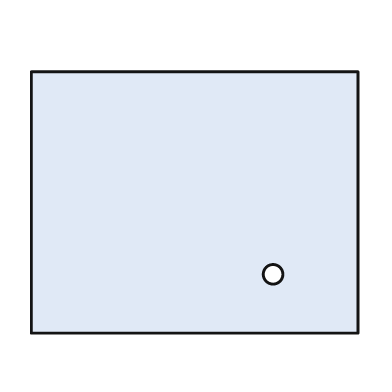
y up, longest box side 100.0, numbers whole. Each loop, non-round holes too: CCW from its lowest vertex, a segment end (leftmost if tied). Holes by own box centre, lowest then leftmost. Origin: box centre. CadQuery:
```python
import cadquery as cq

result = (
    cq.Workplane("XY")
    .moveTo(-50.0, -40.0)
    .lineTo(50.0, -40.0)
    .lineTo(50.0, 40.0)
    .lineTo(-50.0, 40.0)
    .close()
    .moveTo(24.0, -22.0)
    .circle(3.0)
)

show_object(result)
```